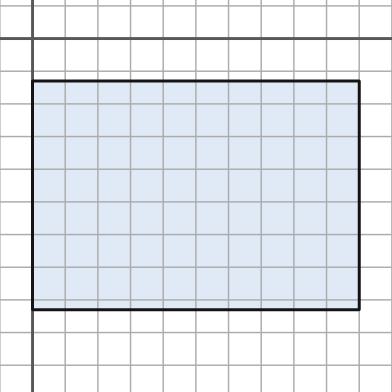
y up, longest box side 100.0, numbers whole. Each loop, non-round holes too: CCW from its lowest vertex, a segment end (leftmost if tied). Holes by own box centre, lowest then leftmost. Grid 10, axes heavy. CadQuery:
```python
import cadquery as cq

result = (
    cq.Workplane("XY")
    .moveTo(0.0, -83.0)
    .lineTo(100.0, -83.0)
    .lineTo(100.0, -13.0)
    .lineTo(0.0, -13.0)
    .close()
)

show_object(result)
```